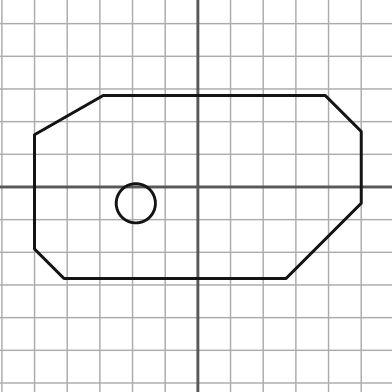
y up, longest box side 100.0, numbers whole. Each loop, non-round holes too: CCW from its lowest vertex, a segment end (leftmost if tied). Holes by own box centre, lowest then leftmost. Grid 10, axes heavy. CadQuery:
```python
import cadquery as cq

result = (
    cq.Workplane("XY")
    .moveTo(-41.0, -28.0)
    .lineTo(27.0, -28.0)
    .lineTo(50.0, -5.0)
    .lineTo(50.0, 17.0)
    .lineTo(39.0, 28.0)
    .lineTo(-29.0, 28.0)
    .lineTo(-50.0, 16.0)
    .lineTo(-50.0, -19.0)
    .close()
    .moveTo(-19.0, -5.0)
    .circle(6.0)
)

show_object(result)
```